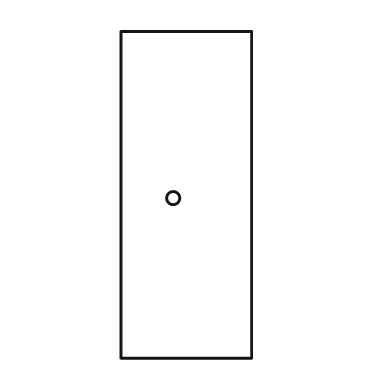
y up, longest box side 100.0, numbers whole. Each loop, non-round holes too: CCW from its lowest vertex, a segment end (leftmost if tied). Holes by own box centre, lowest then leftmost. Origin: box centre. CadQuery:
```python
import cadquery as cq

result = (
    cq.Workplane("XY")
    .moveTo(-20.0, -50.0)
    .lineTo(20.0, -50.0)
    .lineTo(20.0, 50.0)
    .lineTo(-20.0, 50.0)
    .close()
    .moveTo(-4.0, -1.0)
    .circle(2.0)
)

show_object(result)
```